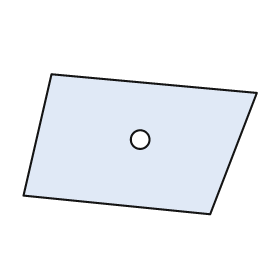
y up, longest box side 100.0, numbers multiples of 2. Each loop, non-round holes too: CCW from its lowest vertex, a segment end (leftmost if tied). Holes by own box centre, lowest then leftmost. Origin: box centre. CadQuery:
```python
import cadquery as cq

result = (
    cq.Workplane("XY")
    .moveTo(30.0, -30.0)
    .lineTo(50.0, 22.0)
    .lineTo(-38.0, 30.0)
    .lineTo(-50.0, -22.0)
    .close()
    .moveTo(0.0, 2.0)
    .circle(4.0)
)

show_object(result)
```